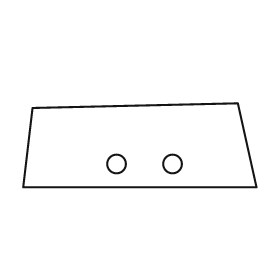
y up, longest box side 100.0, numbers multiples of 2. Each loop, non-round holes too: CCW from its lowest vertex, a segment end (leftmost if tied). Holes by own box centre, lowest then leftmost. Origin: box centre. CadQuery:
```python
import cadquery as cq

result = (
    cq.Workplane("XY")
    .moveTo(-50.0, -18.0)
    .lineTo(50.0, -18.0)
    .lineTo(42.0, 18.0)
    .lineTo(-46.0, 16.0)
    .close()
    .moveTo(-10.0, -8.0)
    .circle(4.0)
    .moveTo(14.0, -8.0)
    .circle(4.0)
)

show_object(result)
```